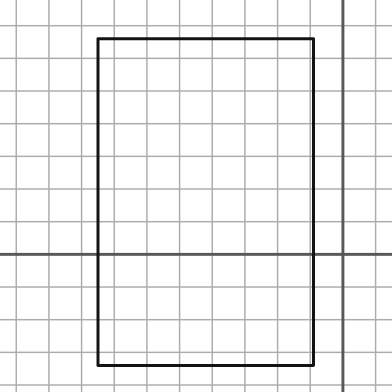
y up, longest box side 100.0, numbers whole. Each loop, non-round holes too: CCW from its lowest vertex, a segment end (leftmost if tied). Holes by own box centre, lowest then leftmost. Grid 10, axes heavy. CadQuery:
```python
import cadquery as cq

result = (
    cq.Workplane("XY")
    .moveTo(-75.0, -34.0)
    .lineTo(-9.0, -34.0)
    .lineTo(-9.0, 66.0)
    .lineTo(-75.0, 66.0)
    .close()
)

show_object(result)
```